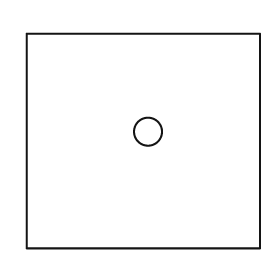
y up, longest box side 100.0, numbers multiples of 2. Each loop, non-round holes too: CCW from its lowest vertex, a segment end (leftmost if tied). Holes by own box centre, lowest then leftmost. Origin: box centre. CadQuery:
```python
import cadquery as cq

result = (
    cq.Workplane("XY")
    .moveTo(-50.0, -46.0)
    .lineTo(50.0, -46.0)
    .lineTo(50.0, 46.0)
    .lineTo(-50.0, 46.0)
    .close()
    .moveTo(2.0, 4.0)
    .circle(6.0)
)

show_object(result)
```